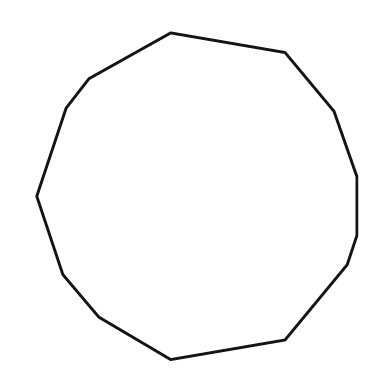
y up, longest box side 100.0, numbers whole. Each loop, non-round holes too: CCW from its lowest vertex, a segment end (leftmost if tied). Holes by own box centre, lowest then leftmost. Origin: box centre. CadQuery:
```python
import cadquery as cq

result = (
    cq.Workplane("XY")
    .moveTo(-8.0, -50.0)
    .lineTo(27.0, -44.0)
    .lineTo(46.0, -21.0)
    .lineTo(49.0, -12.0)
    .lineTo(49.0, 6.0)
    .lineTo(42.0, 26.0)
    .lineTo(27.0, 44.0)
    .lineTo(-8.0, 50.0)
    .lineTo(-33.0, 36.0)
    .lineTo(-40.0, 27.0)
    .lineTo(-49.0, 0.0)
    .lineTo(-41.0, -24.0)
    .lineTo(-30.0, -37.0)
    .close()
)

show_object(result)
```